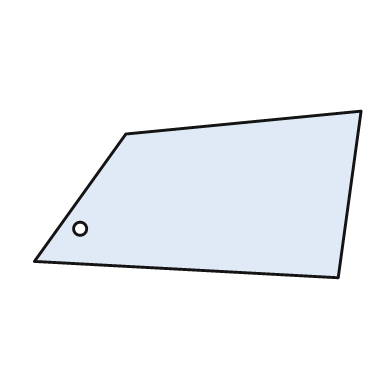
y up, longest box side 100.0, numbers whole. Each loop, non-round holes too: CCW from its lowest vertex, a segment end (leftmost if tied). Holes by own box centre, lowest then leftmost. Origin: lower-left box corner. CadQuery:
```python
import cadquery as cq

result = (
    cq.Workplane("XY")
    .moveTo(93.0, 0.0)
    .lineTo(100.0, 51.0)
    .lineTo(28.0, 44.0)
    .lineTo(0.0, 5.0)
    .close()
    .moveTo(14.0, 15.0)
    .circle(2.0)
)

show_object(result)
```